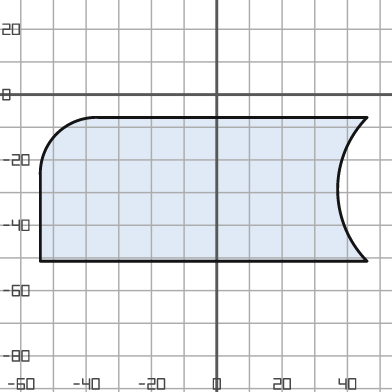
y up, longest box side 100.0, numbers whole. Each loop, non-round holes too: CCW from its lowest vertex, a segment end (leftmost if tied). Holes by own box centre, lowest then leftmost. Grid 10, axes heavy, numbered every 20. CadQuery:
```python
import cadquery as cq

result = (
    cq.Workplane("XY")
    .moveTo(-54.0, -51.0)
    .lineTo(46.0, -51.0)
    .threePointArc((37.0, -29.0), (46.0, -7.0))
    .lineTo(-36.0, -7.0)
    .threePointArc((-49.0, -12.0), (-54.0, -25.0))
    .close()
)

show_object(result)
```